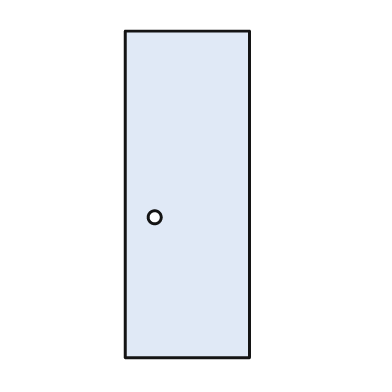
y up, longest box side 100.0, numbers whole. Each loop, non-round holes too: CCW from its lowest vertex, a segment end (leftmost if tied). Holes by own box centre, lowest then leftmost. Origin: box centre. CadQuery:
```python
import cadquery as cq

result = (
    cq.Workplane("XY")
    .moveTo(-19.0, -50.0)
    .lineTo(19.0, -50.0)
    .lineTo(19.0, 50.0)
    .lineTo(-19.0, 50.0)
    .close()
    .moveTo(-10.0, -7.0)
    .circle(2.0)
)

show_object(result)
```